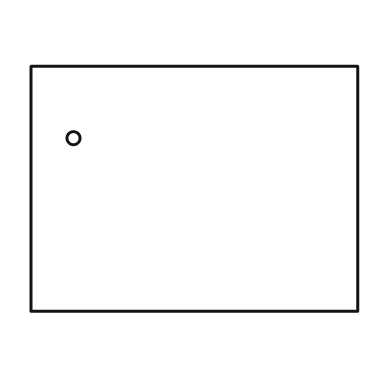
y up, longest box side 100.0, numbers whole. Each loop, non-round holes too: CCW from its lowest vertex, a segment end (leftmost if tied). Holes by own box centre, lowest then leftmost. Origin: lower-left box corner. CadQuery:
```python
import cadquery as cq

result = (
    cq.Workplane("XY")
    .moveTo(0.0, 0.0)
    .lineTo(100.0, 0.0)
    .lineTo(100.0, 75.0)
    .lineTo(0.0, 75.0)
    .close()
    .moveTo(13.0, 53.0)
    .circle(2.0)
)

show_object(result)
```